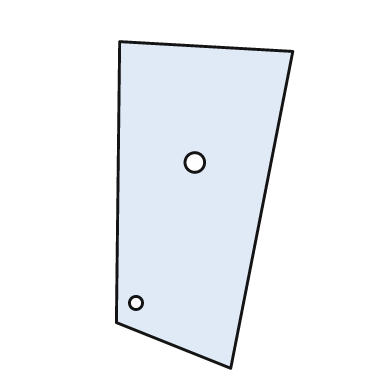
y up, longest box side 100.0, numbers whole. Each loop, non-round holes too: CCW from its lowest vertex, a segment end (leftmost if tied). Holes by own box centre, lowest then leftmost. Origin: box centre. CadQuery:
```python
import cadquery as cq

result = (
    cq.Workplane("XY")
    .moveTo(8.0, -50.0)
    .lineTo(27.0, 47.0)
    .lineTo(-26.0, 50.0)
    .lineTo(-27.0, -36.0)
    .close()
    .moveTo(-21.0, -30.0)
    .circle(2.0)
    .moveTo(-3.0, 13.0)
    .circle(3.0)
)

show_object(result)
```